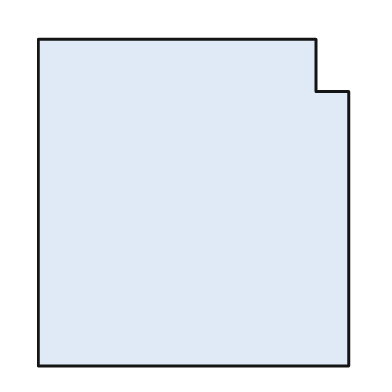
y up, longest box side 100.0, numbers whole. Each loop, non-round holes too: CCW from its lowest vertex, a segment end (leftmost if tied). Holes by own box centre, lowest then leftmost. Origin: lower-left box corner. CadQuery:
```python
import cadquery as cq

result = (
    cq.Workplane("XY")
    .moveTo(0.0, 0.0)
    .lineTo(95.0, 0.0)
    .lineTo(95.0, 84.0)
    .lineTo(85.0, 84.0)
    .lineTo(85.0, 100.0)
    .lineTo(0.0, 100.0)
    .close()
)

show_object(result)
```